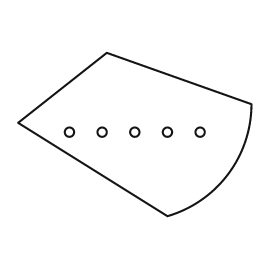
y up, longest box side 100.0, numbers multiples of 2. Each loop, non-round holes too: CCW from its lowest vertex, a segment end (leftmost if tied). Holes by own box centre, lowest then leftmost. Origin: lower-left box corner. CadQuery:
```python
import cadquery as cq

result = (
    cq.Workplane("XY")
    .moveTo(64.0, 0.0)
    .threePointArc((90.0, 18.0), (100.0, 48.0))
    .lineTo(38.0, 70.0)
    .lineTo(0.0, 40.0)
    .close()
    .moveTo(22.0, 36.0)
    .circle(2.0)
    .moveTo(36.0, 36.0)
    .circle(2.0)
    .moveTo(50.0, 36.0)
    .circle(2.0)
    .moveTo(64.0, 36.0)
    .circle(2.0)
    .moveTo(78.0, 36.0)
    .circle(2.0)
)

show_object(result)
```